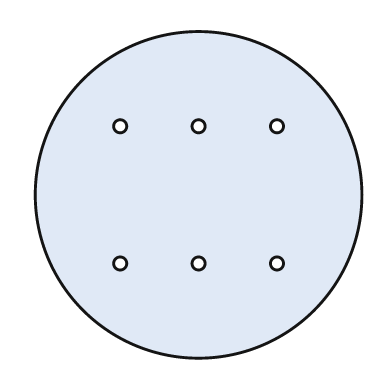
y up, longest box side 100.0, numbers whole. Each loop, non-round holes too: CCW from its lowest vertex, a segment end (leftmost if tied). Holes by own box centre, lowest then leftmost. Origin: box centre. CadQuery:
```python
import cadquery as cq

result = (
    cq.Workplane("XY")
    .moveTo(0.0, 0.0)
    .circle(50.0)
    .moveTo(-24.0, -21.0)
    .circle(2.0)
    .moveTo(0.0, -21.0)
    .circle(2.0)
    .moveTo(24.0, -21.0)
    .circle(2.0)
    .moveTo(-24.0, 21.0)
    .circle(2.0)
    .moveTo(0.0, 21.0)
    .circle(2.0)
    .moveTo(24.0, 21.0)
    .circle(2.0)
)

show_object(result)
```